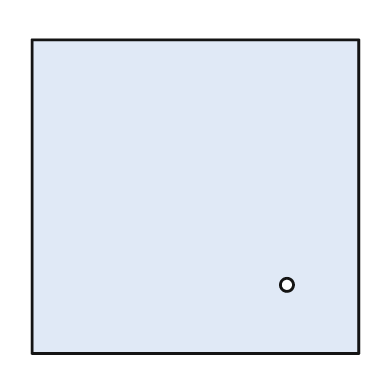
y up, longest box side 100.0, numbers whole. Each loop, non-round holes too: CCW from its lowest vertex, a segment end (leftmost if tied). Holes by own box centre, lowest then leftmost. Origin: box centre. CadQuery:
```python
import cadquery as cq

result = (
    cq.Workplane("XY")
    .moveTo(-50.0, -48.0)
    .lineTo(50.0, -48.0)
    .lineTo(50.0, 48.0)
    .lineTo(-50.0, 48.0)
    .close()
    .moveTo(28.0, -27.0)
    .circle(2.0)
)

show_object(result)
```